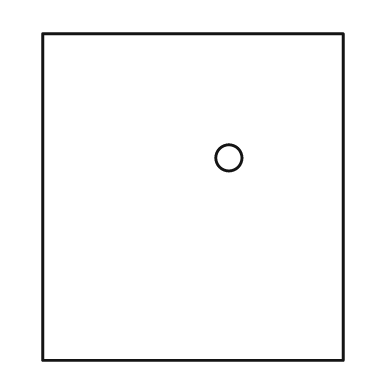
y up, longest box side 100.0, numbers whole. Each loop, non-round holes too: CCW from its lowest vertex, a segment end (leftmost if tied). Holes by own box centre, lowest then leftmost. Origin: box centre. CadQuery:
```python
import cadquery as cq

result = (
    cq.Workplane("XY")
    .moveTo(-46.0, -50.0)
    .lineTo(46.0, -50.0)
    .lineTo(46.0, 50.0)
    .lineTo(-46.0, 50.0)
    .close()
    .moveTo(11.0, 12.0)
    .circle(4.0)
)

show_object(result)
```